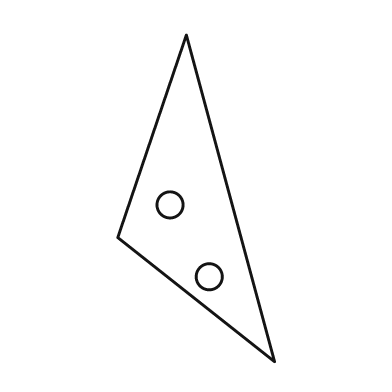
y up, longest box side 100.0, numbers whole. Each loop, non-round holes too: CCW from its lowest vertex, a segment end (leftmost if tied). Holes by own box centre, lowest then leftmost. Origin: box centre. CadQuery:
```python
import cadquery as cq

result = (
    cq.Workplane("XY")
    .moveTo(24.0, -50.0)
    .lineTo(-3.0, 50.0)
    .lineTo(-24.0, -12.0)
    .close()
    .moveTo(4.0, -24.0)
    .circle(4.0)
    .moveTo(-8.0, -2.0)
    .circle(4.0)
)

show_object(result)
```